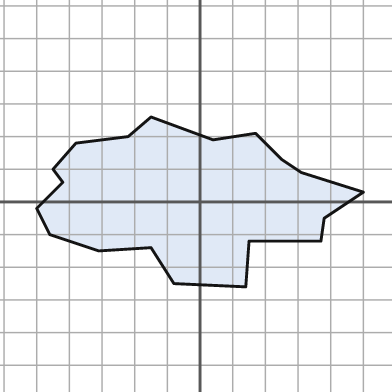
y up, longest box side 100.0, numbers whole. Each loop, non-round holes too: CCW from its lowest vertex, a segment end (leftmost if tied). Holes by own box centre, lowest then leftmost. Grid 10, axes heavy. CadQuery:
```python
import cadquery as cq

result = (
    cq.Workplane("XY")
    .moveTo(14.0, -26.0)
    .lineTo(15.0, -12.0)
    .lineTo(37.0, -12.0)
    .lineTo(38.0, -5.0)
    .lineTo(50.0, 3.0)
    .lineTo(31.0, 9.0)
    .lineTo(25.0, 13.0)
    .lineTo(17.0, 21.0)
    .lineTo(4.0, 19.0)
    .lineTo(-15.0, 26.0)
    .lineTo(-22.0, 20.0)
    .lineTo(-38.0, 18.0)
    .lineTo(-45.0, 10.0)
    .lineTo(-42.0, 6.0)
    .lineTo(-50.0, -2.0)
    .lineTo(-46.0, -10.0)
    .lineTo(-31.0, -15.0)
    .lineTo(-15.0, -14.0)
    .lineTo(-8.0, -25.0)
    .close()
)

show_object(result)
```